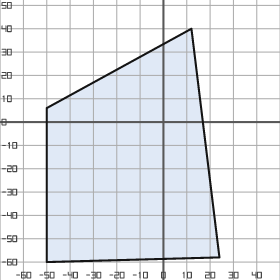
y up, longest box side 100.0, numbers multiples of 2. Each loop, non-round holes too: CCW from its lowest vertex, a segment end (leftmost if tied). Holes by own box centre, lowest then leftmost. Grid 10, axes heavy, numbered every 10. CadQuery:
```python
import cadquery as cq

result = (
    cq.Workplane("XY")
    .moveTo(-50.0, -60.0)
    .lineTo(24.0, -58.0)
    .lineTo(12.0, 40.0)
    .lineTo(-50.0, 6.0)
    .close()
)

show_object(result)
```